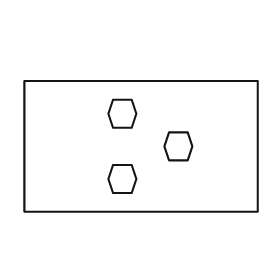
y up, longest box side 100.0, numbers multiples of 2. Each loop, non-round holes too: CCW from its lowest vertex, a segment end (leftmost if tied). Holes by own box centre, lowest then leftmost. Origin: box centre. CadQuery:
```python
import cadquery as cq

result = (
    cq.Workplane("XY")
    .moveTo(-50.0, -28.0)
    .lineTo(50.0, -28.0)
    .lineTo(50.0, 28.0)
    .lineTo(-50.0, 28.0)
    .close()
    .moveTo(-12.0, -20.0)
    .lineTo(-4.0, -20.0)
    .lineTo(-2.0, -14.0)
    .lineTo(-4.0, -8.0)
    .lineTo(-12.0, -8.0)
    .lineTo(-14.0, -14.0)
    .close()
    .moveTo(12.0, -6.0)
    .lineTo(20.0, -6.0)
    .lineTo(22.0, 0.0)
    .lineTo(20.0, 6.0)
    .lineTo(12.0, 6.0)
    .lineTo(10.0, 0.0)
    .close()
    .moveTo(-12.0, 8.0)
    .lineTo(-4.0, 8.0)
    .lineTo(-2.0, 14.0)
    .lineTo(-4.0, 20.0)
    .lineTo(-12.0, 20.0)
    .lineTo(-14.0, 14.0)
    .close()
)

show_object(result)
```